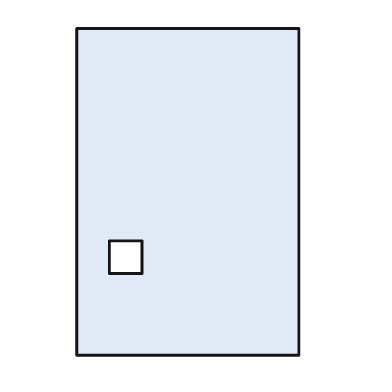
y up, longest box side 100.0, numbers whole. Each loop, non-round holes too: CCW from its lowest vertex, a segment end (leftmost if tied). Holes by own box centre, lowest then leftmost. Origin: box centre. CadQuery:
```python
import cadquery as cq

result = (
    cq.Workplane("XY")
    .moveTo(-34.0, -50.0)
    .lineTo(34.0, -50.0)
    .lineTo(34.0, 50.0)
    .lineTo(-34.0, 50.0)
    .close()
    .moveTo(-24.0, -25.0)
    .lineTo(-14.0, -25.0)
    .lineTo(-14.0, -15.0)
    .lineTo(-24.0, -15.0)
    .close()
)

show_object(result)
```